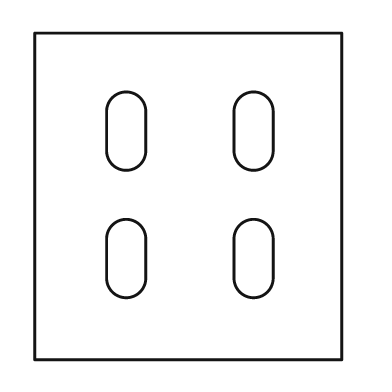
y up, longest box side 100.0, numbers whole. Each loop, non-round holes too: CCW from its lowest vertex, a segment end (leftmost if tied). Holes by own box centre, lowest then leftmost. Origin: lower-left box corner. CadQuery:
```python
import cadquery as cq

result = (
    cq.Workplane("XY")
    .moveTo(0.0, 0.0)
    .lineTo(94.0, 0.0)
    .lineTo(94.0, 100.0)
    .lineTo(0.0, 100.0)
    .close()
    .moveTo(22.0, 25.0)
    .threePointArc((28.0, 19.0), (34.0, 25.0))
    .lineTo(34.0, 37.0)
    .threePointArc((28.0, 43.0), (22.0, 37.0))
    .close()
    .moveTo(61.0, 25.0)
    .threePointArc((67.0, 19.0), (73.0, 25.0))
    .lineTo(73.0, 37.0)
    .threePointArc((67.0, 43.0), (61.0, 37.0))
    .close()
    .moveTo(22.0, 64.0)
    .threePointArc((28.0, 58.0), (34.0, 64.0))
    .lineTo(34.0, 76.0)
    .threePointArc((28.0, 82.0), (22.0, 76.0))
    .close()
    .moveTo(61.0, 64.0)
    .threePointArc((67.0, 58.0), (73.0, 64.0))
    .lineTo(73.0, 76.0)
    .threePointArc((67.0, 82.0), (61.0, 76.0))
    .close()
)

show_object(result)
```